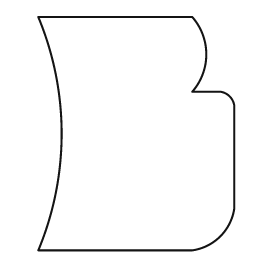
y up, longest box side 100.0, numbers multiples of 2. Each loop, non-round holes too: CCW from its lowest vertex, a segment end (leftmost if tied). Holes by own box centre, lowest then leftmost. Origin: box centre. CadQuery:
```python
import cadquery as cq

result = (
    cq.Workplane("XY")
    .moveTo(-42.0, -50.0)
    .lineTo(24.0, -50.0)
    .threePointArc((36.0, -44.0), (42.0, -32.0))
    .lineTo(42.0, 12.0)
    .threePointArc((40.0, 16.0), (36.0, 18.0))
    .lineTo(24.0, 18.0)
    .threePointArc((30.0, 34.0), (24.0, 50.0))
    .lineTo(-42.0, 50.0)
    .threePointArc((-32.0, 0.0), (-42.0, -50.0))
    .close()
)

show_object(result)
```